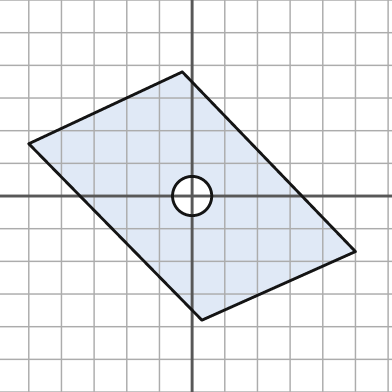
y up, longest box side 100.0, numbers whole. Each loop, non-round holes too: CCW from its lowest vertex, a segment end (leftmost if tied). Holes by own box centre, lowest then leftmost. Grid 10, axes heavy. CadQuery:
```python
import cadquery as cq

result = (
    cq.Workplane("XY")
    .moveTo(3.0, -38.0)
    .lineTo(50.0, -17.0)
    .lineTo(-3.0, 38.0)
    .lineTo(-50.0, 16.0)
    .close()
    .moveTo(0.0, 0.0)
    .circle(6.0)
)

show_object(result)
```